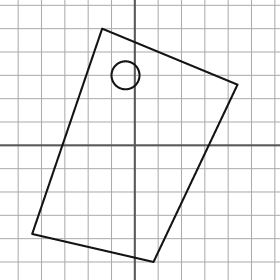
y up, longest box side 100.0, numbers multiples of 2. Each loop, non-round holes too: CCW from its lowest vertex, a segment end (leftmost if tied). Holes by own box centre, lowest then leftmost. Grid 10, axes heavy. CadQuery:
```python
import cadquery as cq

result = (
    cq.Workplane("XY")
    .moveTo(8.0, -50.0)
    .lineTo(44.0, 26.0)
    .lineTo(-14.0, 50.0)
    .lineTo(-44.0, -38.0)
    .close()
    .moveTo(-4.0, 30.0)
    .circle(6.0)
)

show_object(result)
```